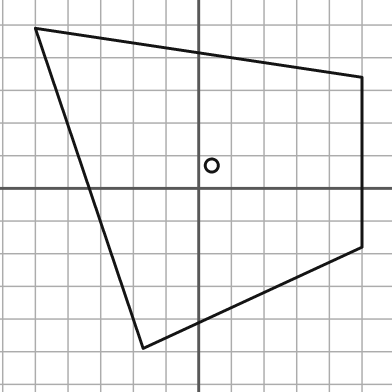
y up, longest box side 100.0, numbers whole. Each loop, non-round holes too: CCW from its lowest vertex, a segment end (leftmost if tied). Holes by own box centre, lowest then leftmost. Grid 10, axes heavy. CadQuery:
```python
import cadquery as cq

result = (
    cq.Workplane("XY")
    .moveTo(-17.0, -49.0)
    .lineTo(50.0, -18.0)
    .lineTo(50.0, 34.0)
    .lineTo(-50.0, 49.0)
    .close()
    .moveTo(4.0, 7.0)
    .circle(2.0)
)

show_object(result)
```